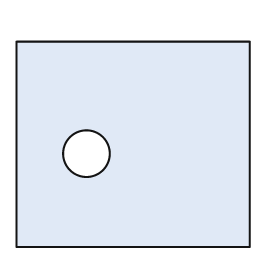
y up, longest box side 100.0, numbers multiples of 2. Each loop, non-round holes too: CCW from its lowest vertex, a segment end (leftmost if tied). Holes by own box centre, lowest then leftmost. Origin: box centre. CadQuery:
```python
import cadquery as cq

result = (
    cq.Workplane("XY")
    .moveTo(-50.0, -44.0)
    .lineTo(50.0, -44.0)
    .lineTo(50.0, 44.0)
    .lineTo(-50.0, 44.0)
    .close()
    .moveTo(-20.0, -4.0)
    .circle(10.0)
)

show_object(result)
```